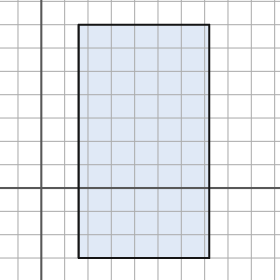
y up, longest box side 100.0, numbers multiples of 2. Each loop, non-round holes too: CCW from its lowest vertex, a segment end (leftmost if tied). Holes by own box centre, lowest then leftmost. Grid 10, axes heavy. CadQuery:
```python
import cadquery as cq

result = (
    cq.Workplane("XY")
    .moveTo(16.0, -30.0)
    .lineTo(72.0, -30.0)
    .lineTo(72.0, 70.0)
    .lineTo(16.0, 70.0)
    .close()
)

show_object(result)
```